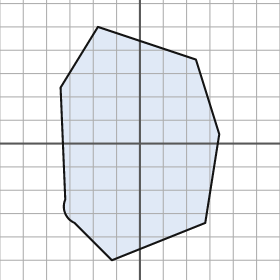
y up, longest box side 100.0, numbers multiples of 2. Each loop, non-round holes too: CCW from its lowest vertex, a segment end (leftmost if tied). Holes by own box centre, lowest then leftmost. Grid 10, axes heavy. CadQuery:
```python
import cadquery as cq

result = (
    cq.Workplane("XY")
    .moveTo(-12.0, -50.0)
    .lineTo(28.0, -34.0)
    .lineTo(34.0, 4.0)
    .lineTo(24.0, 36.0)
    .lineTo(-18.0, 50.0)
    .lineTo(-34.0, 24.0)
    .lineTo(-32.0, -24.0)
    .threePointArc((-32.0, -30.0), (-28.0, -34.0))
    .close()
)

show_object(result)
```